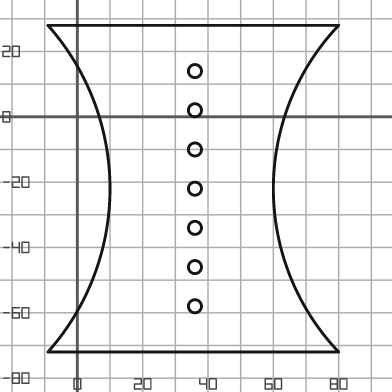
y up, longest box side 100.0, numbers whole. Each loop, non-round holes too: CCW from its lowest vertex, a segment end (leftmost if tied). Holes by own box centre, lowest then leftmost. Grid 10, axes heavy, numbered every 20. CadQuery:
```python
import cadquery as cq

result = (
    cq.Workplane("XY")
    .moveTo(-9.0, -72.0)
    .lineTo(80.0, -72.0)
    .threePointArc((60.0, -22.0), (80.0, 28.0))
    .lineTo(-9.0, 28.0)
    .threePointArc((10.0, -22.0), (-9.0, -72.0))
    .close()
    .moveTo(36.0, -58.0)
    .circle(2.0)
    .moveTo(36.0, -46.0)
    .circle(2.0)
    .moveTo(36.0, -34.0)
    .circle(2.0)
    .moveTo(36.0, -22.0)
    .circle(2.0)
    .moveTo(36.0, -10.0)
    .circle(2.0)
    .moveTo(36.0, 2.0)
    .circle(2.0)
    .moveTo(36.0, 14.0)
    .circle(2.0)
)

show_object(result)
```